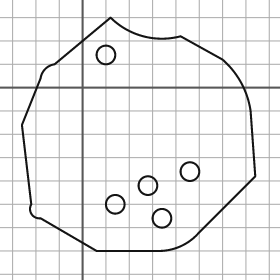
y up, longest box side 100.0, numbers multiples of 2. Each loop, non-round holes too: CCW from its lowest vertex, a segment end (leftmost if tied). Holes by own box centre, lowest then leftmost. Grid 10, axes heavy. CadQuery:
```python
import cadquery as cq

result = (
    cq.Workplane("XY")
    .moveTo(6.0, -70.0)
    .lineTo(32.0, -70.0)
    .threePointArc((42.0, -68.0), (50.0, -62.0))
    .lineTo(74.0, -38.0)
    .lineTo(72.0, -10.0)
    .threePointArc((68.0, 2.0), (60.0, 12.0))
    .lineTo(42.0, 22.0)
    .threePointArc((26.0, 22.0), (12.0, 30.0))
    .lineTo(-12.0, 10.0)
    .threePointArc((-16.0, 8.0), (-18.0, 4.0))
    .lineTo(-26.0, -16.0)
    .lineTo(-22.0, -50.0)
    .threePointArc((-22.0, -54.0), (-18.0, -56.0))
    .close()
    .moveTo(34.0, -56.0)
    .circle(4.0)
    .moveTo(14.0, -50.0)
    .circle(4.0)
    .moveTo(28.0, -42.0)
    .circle(4.0)
    .moveTo(46.0, -36.0)
    .circle(4.0)
    .moveTo(10.0, 14.0)
    .circle(4.0)
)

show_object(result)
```